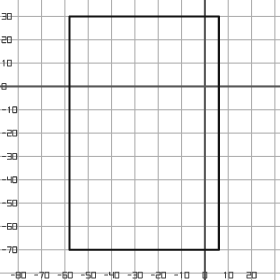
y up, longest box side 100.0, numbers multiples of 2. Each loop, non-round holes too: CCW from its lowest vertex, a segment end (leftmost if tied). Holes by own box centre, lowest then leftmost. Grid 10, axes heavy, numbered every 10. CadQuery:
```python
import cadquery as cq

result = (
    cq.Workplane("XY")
    .moveTo(-58.0, -70.0)
    .lineTo(6.0, -70.0)
    .lineTo(6.0, 30.0)
    .lineTo(-58.0, 30.0)
    .close()
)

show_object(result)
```